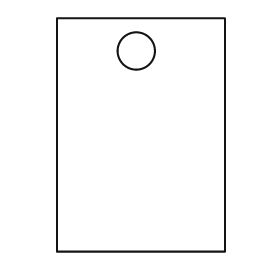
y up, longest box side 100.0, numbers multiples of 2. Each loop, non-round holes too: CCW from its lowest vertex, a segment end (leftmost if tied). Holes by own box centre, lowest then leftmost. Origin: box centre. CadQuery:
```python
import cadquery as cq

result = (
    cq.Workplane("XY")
    .moveTo(-36.0, -50.0)
    .lineTo(36.0, -50.0)
    .lineTo(36.0, 50.0)
    .lineTo(-36.0, 50.0)
    .close()
    .moveTo(-2.0, 36.0)
    .circle(8.0)
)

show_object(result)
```